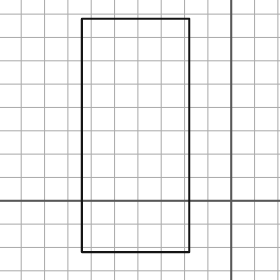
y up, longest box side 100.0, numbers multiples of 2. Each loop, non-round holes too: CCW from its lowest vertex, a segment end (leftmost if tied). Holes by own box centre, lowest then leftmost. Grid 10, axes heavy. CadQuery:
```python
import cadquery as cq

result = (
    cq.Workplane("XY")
    .moveTo(-64.0, -22.0)
    .lineTo(-18.0, -22.0)
    .lineTo(-18.0, 78.0)
    .lineTo(-64.0, 78.0)
    .close()
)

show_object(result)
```